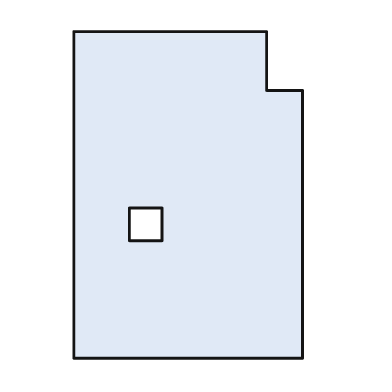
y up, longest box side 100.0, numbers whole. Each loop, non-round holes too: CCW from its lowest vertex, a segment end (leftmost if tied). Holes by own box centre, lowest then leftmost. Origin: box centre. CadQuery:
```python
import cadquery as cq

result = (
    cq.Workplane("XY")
    .moveTo(-35.0, -50.0)
    .lineTo(35.0, -50.0)
    .lineTo(35.0, 32.0)
    .lineTo(24.0, 32.0)
    .lineTo(24.0, 50.0)
    .lineTo(-35.0, 50.0)
    .close()
    .moveTo(-18.0, -14.0)
    .lineTo(-8.0, -14.0)
    .lineTo(-8.0, -4.0)
    .lineTo(-18.0, -4.0)
    .close()
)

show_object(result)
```